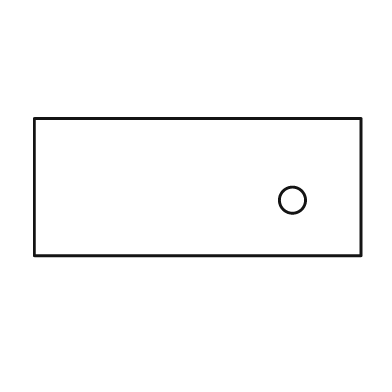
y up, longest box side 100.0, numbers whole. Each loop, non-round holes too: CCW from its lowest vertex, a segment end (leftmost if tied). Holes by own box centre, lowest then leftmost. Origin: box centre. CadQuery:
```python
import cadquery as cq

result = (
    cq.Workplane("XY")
    .moveTo(-50.0, -21.0)
    .lineTo(50.0, -21.0)
    .lineTo(50.0, 21.0)
    .lineTo(-50.0, 21.0)
    .close()
    .moveTo(29.0, -4.0)
    .circle(4.0)
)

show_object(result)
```